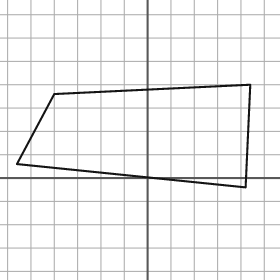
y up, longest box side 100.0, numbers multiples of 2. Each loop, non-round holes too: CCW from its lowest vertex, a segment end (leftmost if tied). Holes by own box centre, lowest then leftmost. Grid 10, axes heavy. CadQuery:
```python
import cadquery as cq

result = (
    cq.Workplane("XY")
    .moveTo(42.0, -4.0)
    .lineTo(44.0, 40.0)
    .lineTo(-40.0, 36.0)
    .lineTo(-56.0, 6.0)
    .close()
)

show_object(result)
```